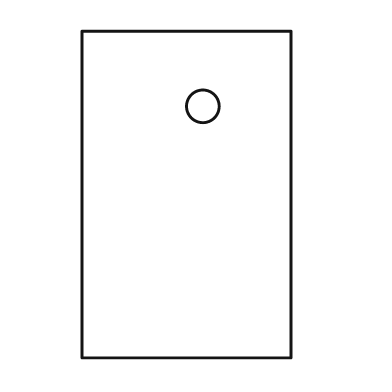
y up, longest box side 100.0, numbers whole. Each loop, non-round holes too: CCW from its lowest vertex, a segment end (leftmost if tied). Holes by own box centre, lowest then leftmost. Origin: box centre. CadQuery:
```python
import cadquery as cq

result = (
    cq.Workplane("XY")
    .moveTo(-32.0, -50.0)
    .lineTo(32.0, -50.0)
    .lineTo(32.0, 50.0)
    .lineTo(-32.0, 50.0)
    .close()
    .moveTo(5.0, 27.0)
    .circle(5.0)
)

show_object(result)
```